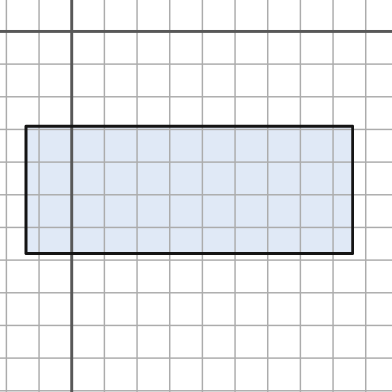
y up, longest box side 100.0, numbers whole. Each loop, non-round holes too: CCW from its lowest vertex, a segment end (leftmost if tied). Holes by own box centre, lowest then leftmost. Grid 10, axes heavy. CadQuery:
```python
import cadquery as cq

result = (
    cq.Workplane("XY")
    .moveTo(-14.0, -68.0)
    .lineTo(86.0, -68.0)
    .lineTo(86.0, -29.0)
    .lineTo(-14.0, -29.0)
    .close()
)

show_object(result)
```